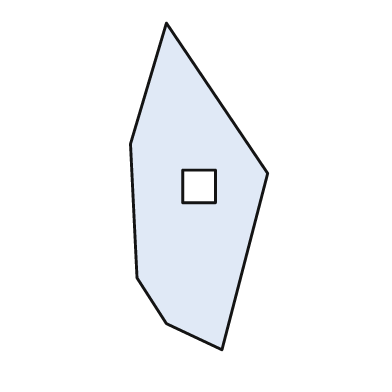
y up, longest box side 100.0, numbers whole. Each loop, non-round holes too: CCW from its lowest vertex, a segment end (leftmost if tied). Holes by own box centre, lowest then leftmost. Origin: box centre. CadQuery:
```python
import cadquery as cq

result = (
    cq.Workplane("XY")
    .moveTo(7.0, -50.0)
    .lineTo(21.0, 4.0)
    .lineTo(-10.0, 50.0)
    .lineTo(-21.0, 13.0)
    .lineTo(-19.0, -28.0)
    .lineTo(-10.0, -42.0)
    .close()
    .moveTo(-5.0, -5.0)
    .lineTo(5.0, -5.0)
    .lineTo(5.0, 5.0)
    .lineTo(-5.0, 5.0)
    .close()
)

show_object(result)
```